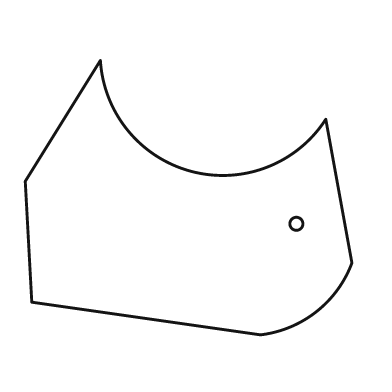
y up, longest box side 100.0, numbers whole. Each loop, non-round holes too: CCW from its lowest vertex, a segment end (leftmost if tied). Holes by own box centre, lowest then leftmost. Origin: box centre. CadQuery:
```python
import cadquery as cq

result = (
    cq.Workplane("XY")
    .moveTo(22.0, -42.0)
    .threePointArc((39.0, -35.0), (50.0, -20.0))
    .lineTo(42.0, 24.0)
    .threePointArc((1.0, 8.0), (-27.0, 42.0))
    .lineTo(-50.0, 5.0)
    .lineTo(-48.0, -32.0)
    .close()
    .moveTo(33.0, -8.0)
    .circle(2.0)
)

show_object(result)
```